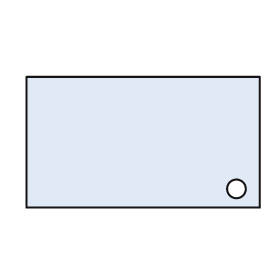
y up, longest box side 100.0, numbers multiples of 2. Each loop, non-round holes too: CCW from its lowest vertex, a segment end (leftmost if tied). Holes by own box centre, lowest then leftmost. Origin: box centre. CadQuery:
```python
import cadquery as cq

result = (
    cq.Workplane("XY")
    .moveTo(-50.0, -28.0)
    .lineTo(50.0, -28.0)
    .lineTo(50.0, 28.0)
    .lineTo(-50.0, 28.0)
    .close()
    .moveTo(40.0, -20.0)
    .circle(4.0)
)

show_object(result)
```